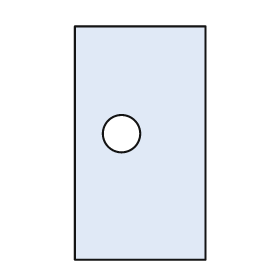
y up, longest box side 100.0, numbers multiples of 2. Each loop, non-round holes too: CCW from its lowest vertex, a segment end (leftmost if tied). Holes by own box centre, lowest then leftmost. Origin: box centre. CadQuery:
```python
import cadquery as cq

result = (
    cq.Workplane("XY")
    .moveTo(-28.0, -50.0)
    .lineTo(28.0, -50.0)
    .lineTo(28.0, 50.0)
    .lineTo(-28.0, 50.0)
    .close()
    .moveTo(-8.0, 4.0)
    .circle(8.0)
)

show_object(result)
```